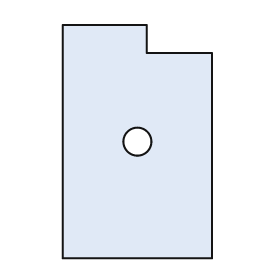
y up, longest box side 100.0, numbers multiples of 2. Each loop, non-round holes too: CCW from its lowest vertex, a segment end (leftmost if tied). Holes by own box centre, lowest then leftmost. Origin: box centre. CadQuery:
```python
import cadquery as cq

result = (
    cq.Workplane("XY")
    .moveTo(-32.0, -50.0)
    .lineTo(32.0, -50.0)
    .lineTo(32.0, 38.0)
    .lineTo(4.0, 38.0)
    .lineTo(4.0, 50.0)
    .lineTo(-32.0, 50.0)
    .close()
    .moveTo(0.0, 0.0)
    .circle(6.0)
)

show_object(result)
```